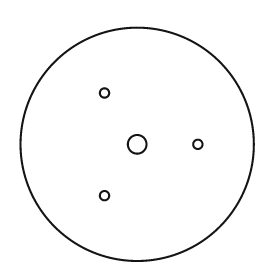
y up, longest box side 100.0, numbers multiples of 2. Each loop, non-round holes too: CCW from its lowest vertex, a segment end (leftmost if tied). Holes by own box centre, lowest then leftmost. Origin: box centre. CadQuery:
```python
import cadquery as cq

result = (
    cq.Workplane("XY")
    .moveTo(0.0, 0.0)
    .circle(50.0)
    .moveTo(-14.0, -22.0)
    .circle(2.0)
    .moveTo(0.0, 0.0)
    .circle(4.0)
    .moveTo(26.0, 0.0)
    .circle(2.0)
    .moveTo(-14.0, 22.0)
    .circle(2.0)
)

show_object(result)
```